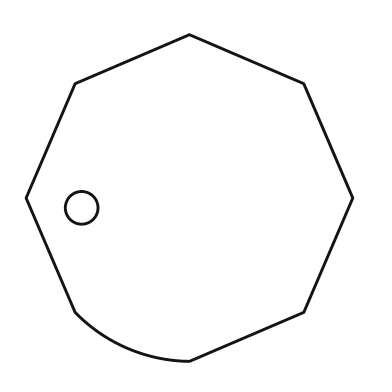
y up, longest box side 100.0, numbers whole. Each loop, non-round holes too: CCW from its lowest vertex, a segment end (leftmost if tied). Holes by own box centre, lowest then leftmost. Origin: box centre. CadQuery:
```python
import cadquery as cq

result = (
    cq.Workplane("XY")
    .moveTo(0.0, -50.0)
    .lineTo(35.0, -35.0)
    .lineTo(50.0, 0.0)
    .lineTo(35.0, 35.0)
    .lineTo(0.0, 50.0)
    .lineTo(-35.0, 35.0)
    .lineTo(-50.0, 0.0)
    .lineTo(-35.0, -35.0)
    .threePointArc((-19.0, -46.0), (0.0, -50.0))
    .close()
    .moveTo(-33.0, -3.0)
    .circle(5.0)
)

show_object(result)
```